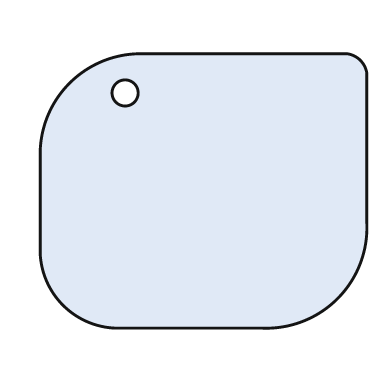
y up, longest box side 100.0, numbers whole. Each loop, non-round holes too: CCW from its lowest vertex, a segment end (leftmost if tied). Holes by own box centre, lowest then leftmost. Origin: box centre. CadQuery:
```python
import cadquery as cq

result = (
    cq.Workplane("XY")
    .moveTo(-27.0, -42.0)
    .lineTo(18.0, -42.0)
    .threePointArc((41.0, -33.0), (50.0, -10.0))
    .lineTo(50.0, 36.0)
    .threePointArc((48.0, 40.0), (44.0, 42.0))
    .lineTo(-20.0, 42.0)
    .threePointArc((-41.0, 33.0), (-50.0, 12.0))
    .lineTo(-50.0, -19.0)
    .threePointArc((-43.0, -35.0), (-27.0, -42.0))
    .close()
    .moveTo(-24.0, 30.0)
    .circle(4.0)
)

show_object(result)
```